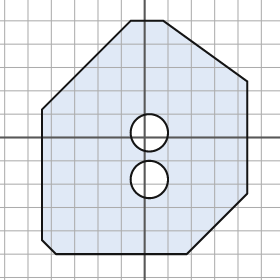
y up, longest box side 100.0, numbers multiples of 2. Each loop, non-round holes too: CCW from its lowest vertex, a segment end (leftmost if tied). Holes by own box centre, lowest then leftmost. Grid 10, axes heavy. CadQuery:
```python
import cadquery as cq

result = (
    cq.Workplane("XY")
    .moveTo(-38.0, -50.0)
    .lineTo(18.0, -50.0)
    .lineTo(44.0, -24.0)
    .lineTo(44.0, 24.0)
    .lineTo(8.0, 50.0)
    .lineTo(-6.0, 50.0)
    .lineTo(-44.0, 12.0)
    .lineTo(-44.0, -44.0)
    .close()
    .moveTo(2.0, -18.0)
    .circle(8.0)
    .moveTo(2.0, 2.0)
    .circle(8.0)
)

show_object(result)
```